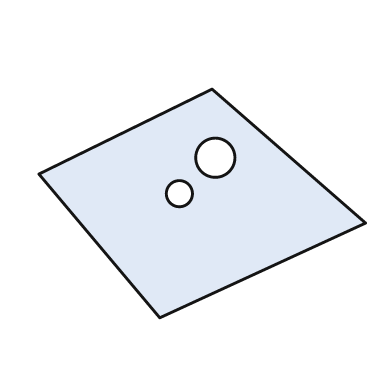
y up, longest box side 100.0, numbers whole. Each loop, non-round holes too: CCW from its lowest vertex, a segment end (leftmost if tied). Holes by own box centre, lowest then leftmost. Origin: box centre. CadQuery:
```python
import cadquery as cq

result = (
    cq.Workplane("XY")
    .moveTo(-13.0, -35.0)
    .lineTo(50.0, -6.0)
    .lineTo(3.0, 35.0)
    .lineTo(-50.0, 9.0)
    .close()
    .moveTo(-7.0, 3.0)
    .circle(4.0)
    .moveTo(4.0, 14.0)
    .circle(6.0)
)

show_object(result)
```